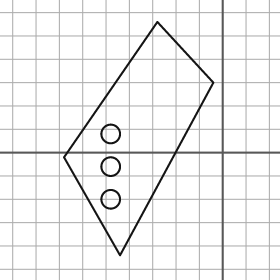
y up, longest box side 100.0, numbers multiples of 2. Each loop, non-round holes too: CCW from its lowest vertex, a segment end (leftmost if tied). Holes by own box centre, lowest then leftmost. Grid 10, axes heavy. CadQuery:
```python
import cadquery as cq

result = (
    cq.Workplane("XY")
    .moveTo(-44.0, -44.0)
    .lineTo(-4.0, 30.0)
    .lineTo(-28.0, 56.0)
    .lineTo(-68.0, -2.0)
    .close()
    .moveTo(-48.0, -20.0)
    .circle(4.0)
    .moveTo(-48.0, -6.0)
    .circle(4.0)
    .moveTo(-48.0, 8.0)
    .circle(4.0)
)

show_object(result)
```